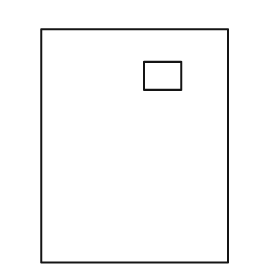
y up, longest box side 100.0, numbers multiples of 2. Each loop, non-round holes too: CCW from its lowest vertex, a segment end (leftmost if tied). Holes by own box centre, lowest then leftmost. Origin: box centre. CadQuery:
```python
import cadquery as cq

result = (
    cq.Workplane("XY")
    .moveTo(-40.0, -50.0)
    .lineTo(40.0, -50.0)
    .lineTo(40.0, 50.0)
    .lineTo(-40.0, 50.0)
    .close()
    .moveTo(4.0, 24.0)
    .lineTo(20.0, 24.0)
    .lineTo(20.0, 36.0)
    .lineTo(4.0, 36.0)
    .close()
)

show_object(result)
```